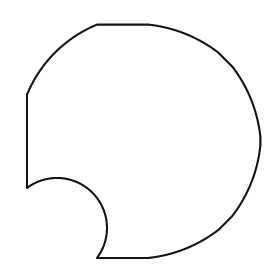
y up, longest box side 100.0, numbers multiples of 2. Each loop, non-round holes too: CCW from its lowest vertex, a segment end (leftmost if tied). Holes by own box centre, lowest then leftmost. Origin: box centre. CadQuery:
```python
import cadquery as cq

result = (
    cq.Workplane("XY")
    .moveTo(-20.0, -50.0)
    .lineTo(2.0, -50.0)
    .threePointArc((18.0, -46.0), (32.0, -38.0))
    .lineTo(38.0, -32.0)
    .threePointArc((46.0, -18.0), (50.0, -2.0))
    .lineTo(50.0, 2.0)
    .threePointArc((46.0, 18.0), (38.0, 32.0))
    .lineTo(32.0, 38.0)
    .threePointArc((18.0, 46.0), (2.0, 50.0))
    .lineTo(-20.0, 50.0)
    .threePointArc((-38.0, 38.0), (-50.0, 20.0))
    .lineTo(-50.0, -20.0)
    .threePointArc((-22.0, -22.0), (-20.0, -50.0))
    .close()
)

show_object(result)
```